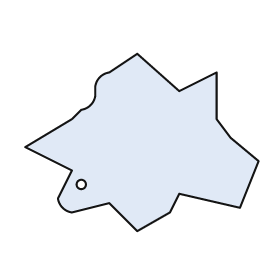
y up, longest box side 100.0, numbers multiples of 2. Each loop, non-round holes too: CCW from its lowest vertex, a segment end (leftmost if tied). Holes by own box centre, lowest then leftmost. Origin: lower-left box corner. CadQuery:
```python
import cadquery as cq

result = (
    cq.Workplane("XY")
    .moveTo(48.0, 0.0)
    .lineTo(62.0, 8.0)
    .lineTo(66.0, 16.0)
    .lineTo(92.0, 10.0)
    .lineTo(100.0, 30.0)
    .lineTo(88.0, 40.0)
    .lineTo(82.0, 48.0)
    .lineTo(82.0, 68.0)
    .lineTo(66.0, 60.0)
    .lineTo(48.0, 76.0)
    .lineTo(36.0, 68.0)
    .threePointArc((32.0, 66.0), (30.0, 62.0))
    .lineTo(30.0, 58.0)
    .threePointArc((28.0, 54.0), (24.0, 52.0))
    .lineTo(20.0, 48.0)
    .lineTo(0.0, 36.0)
    .lineTo(20.0, 26.0)
    .lineTo(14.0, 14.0)
    .threePointArc((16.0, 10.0), (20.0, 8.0))
    .lineTo(36.0, 12.0)
    .close()
    .moveTo(24.0, 20.0)
    .circle(2.0)
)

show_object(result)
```